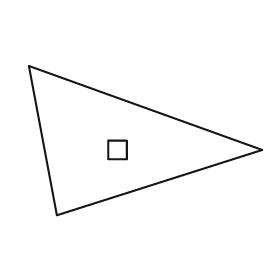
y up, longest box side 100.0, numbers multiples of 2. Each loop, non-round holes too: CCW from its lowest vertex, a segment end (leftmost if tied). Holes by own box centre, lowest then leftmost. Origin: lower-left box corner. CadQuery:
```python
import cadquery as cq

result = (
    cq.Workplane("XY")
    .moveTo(12.0, 0.0)
    .lineTo(100.0, 28.0)
    .lineTo(0.0, 64.0)
    .close()
    .moveTo(34.0, 24.0)
    .lineTo(42.0, 24.0)
    .lineTo(42.0, 32.0)
    .lineTo(34.0, 32.0)
    .close()
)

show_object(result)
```